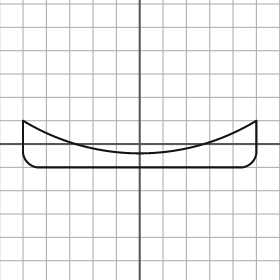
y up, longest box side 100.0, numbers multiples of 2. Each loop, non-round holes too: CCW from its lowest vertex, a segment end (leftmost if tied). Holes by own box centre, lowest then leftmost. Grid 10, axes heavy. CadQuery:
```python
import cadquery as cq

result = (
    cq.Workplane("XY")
    .moveTo(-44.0, -10.0)
    .lineTo(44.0, -10.0)
    .threePointArc((48.0, -8.0), (50.0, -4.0))
    .lineTo(50.0, 10.0)
    .threePointArc((0.0, -4.0), (-50.0, 10.0))
    .lineTo(-50.0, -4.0)
    .threePointArc((-48.0, -8.0), (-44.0, -10.0))
    .close()
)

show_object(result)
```